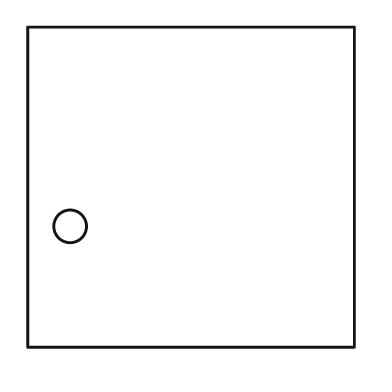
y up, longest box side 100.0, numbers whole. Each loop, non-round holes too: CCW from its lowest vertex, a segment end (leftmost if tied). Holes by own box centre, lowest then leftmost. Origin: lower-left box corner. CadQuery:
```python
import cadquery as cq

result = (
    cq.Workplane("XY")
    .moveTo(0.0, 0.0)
    .lineTo(100.0, 0.0)
    .lineTo(100.0, 98.0)
    .lineTo(0.0, 98.0)
    .close()
    .moveTo(13.0, 37.0)
    .circle(5.0)
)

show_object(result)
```